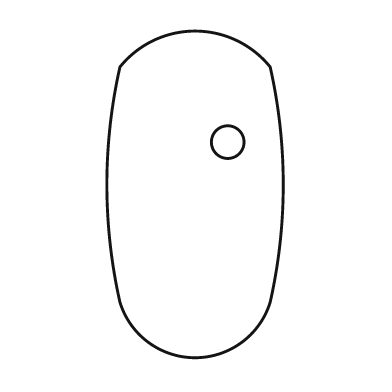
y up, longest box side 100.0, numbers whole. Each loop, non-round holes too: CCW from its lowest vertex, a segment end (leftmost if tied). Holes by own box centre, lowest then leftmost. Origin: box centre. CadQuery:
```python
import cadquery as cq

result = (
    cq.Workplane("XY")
    .moveTo(-23.0, -33.0)
    .threePointArc((0.0, -50.0), (23.0, -33.0))
    .threePointArc((27.0, 3.0), (23.0, 39.0))
    .threePointArc((0.0, 50.0), (-23.0, 39.0))
    .threePointArc((-27.0, 3.0), (-23.0, -33.0))
    .close()
    .moveTo(10.0, 16.0)
    .circle(5.0)
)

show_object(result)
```